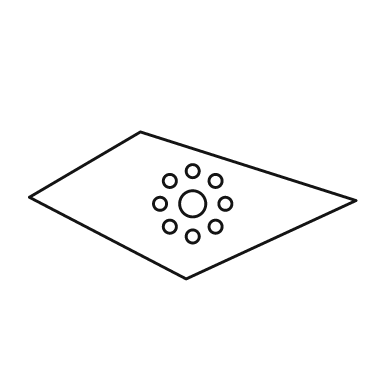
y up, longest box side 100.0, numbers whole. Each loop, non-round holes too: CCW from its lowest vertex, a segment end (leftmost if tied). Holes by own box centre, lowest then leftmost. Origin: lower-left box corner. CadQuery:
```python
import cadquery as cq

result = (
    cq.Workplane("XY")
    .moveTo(48.0, 0.0)
    .lineTo(100.0, 24.0)
    .lineTo(34.0, 45.0)
    .lineTo(0.0, 25.0)
    .close()
    .moveTo(50.0, 13.0)
    .circle(2.0)
    .moveTo(43.0, 16.0)
    .circle(2.0)
    .moveTo(57.0, 16.0)
    .circle(2.0)
    .moveTo(40.0, 23.0)
    .circle(2.0)
    .moveTo(50.0, 23.0)
    .circle(4.0)
    .moveTo(60.0, 23.0)
    .circle(2.0)
    .moveTo(43.0, 30.0)
    .circle(2.0)
    .moveTo(57.0, 30.0)
    .circle(2.0)
    .moveTo(50.0, 33.0)
    .circle(2.0)
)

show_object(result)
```